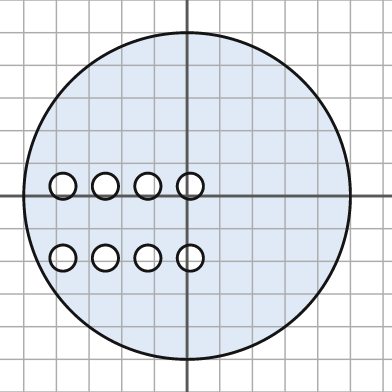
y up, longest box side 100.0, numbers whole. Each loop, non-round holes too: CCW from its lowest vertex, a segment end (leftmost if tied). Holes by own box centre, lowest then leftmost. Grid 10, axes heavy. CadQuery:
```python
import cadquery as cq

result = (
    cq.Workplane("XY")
    .moveTo(0.0, 0.0)
    .circle(50.0)
    .moveTo(-38.0, -19.0)
    .circle(4.0)
    .moveTo(-25.0, -19.0)
    .circle(4.0)
    .moveTo(-12.0, -19.0)
    .circle(4.0)
    .moveTo(1.0, -19.0)
    .circle(4.0)
    .moveTo(-38.0, 3.0)
    .circle(4.0)
    .moveTo(-25.0, 3.0)
    .circle(4.0)
    .moveTo(-12.0, 3.0)
    .circle(4.0)
    .moveTo(1.0, 3.0)
    .circle(4.0)
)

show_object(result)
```